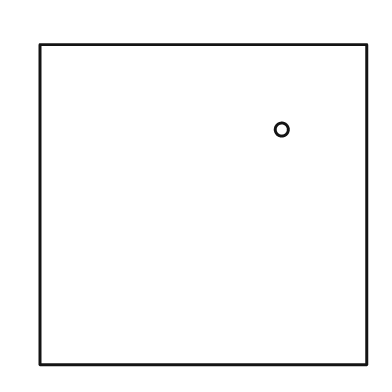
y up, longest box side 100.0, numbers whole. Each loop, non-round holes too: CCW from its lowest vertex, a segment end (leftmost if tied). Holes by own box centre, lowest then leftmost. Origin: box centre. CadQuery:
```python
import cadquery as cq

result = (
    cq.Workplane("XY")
    .moveTo(-50.0, -49.0)
    .lineTo(50.0, -49.0)
    .lineTo(50.0, 49.0)
    .lineTo(-50.0, 49.0)
    .close()
    .moveTo(24.0, 23.0)
    .circle(2.0)
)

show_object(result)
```